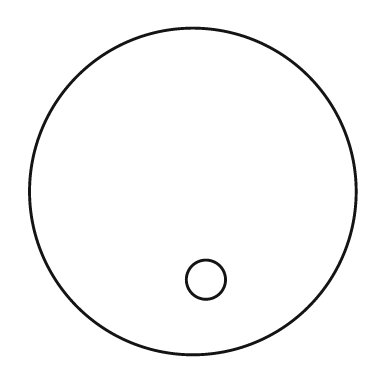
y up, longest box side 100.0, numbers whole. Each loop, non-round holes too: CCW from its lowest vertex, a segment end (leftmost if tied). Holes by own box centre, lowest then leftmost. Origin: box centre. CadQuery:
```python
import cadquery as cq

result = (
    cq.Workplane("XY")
    .moveTo(0.0, 0.0)
    .circle(50.0)
    .moveTo(4.0, -27.0)
    .circle(6.0)
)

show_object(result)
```